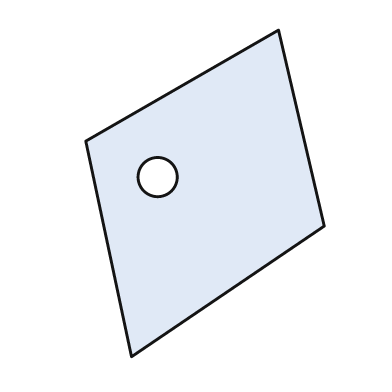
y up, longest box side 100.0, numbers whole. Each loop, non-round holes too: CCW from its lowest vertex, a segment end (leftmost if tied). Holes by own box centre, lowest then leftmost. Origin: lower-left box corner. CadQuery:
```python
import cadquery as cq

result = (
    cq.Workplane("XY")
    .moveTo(14.0, 0.0)
    .lineTo(73.0, 40.0)
    .lineTo(59.0, 100.0)
    .lineTo(0.0, 66.0)
    .close()
    .moveTo(22.0, 55.0)
    .circle(6.0)
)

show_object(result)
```